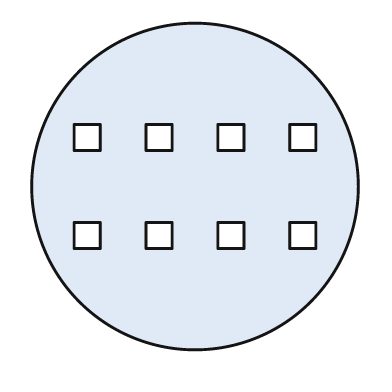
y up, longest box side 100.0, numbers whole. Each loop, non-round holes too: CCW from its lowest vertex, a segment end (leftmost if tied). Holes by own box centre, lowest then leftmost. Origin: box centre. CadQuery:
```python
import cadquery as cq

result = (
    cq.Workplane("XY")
    .moveTo(0.0, 0.0)
    .circle(50.0)
    .moveTo(-37.0, -19.0)
    .lineTo(-29.0, -19.0)
    .lineTo(-29.0, -11.0)
    .lineTo(-37.0, -11.0)
    .close()
    .moveTo(-15.0, -19.0)
    .lineTo(-7.0, -19.0)
    .lineTo(-7.0, -11.0)
    .lineTo(-15.0, -11.0)
    .close()
    .moveTo(7.0, -19.0)
    .lineTo(15.0, -19.0)
    .lineTo(15.0, -11.0)
    .lineTo(7.0, -11.0)
    .close()
    .moveTo(29.0, -19.0)
    .lineTo(37.0, -19.0)
    .lineTo(37.0, -11.0)
    .lineTo(29.0, -11.0)
    .close()
    .moveTo(-37.0, 11.0)
    .lineTo(-29.0, 11.0)
    .lineTo(-29.0, 19.0)
    .lineTo(-37.0, 19.0)
    .close()
    .moveTo(-15.0, 11.0)
    .lineTo(-7.0, 11.0)
    .lineTo(-7.0, 19.0)
    .lineTo(-15.0, 19.0)
    .close()
    .moveTo(7.0, 11.0)
    .lineTo(15.0, 11.0)
    .lineTo(15.0, 19.0)
    .lineTo(7.0, 19.0)
    .close()
    .moveTo(29.0, 11.0)
    .lineTo(37.0, 11.0)
    .lineTo(37.0, 19.0)
    .lineTo(29.0, 19.0)
    .close()
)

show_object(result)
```